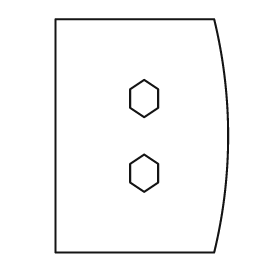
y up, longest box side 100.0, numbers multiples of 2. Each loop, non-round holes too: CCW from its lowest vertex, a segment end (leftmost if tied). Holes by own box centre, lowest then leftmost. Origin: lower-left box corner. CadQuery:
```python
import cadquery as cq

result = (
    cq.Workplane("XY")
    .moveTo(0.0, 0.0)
    .lineTo(68.0, 0.0)
    .threePointArc((74.0, 50.0), (68.0, 100.0))
    .lineTo(0.0, 100.0)
    .close()
    .moveTo(38.0, 26.0)
    .lineTo(44.0, 30.0)
    .lineTo(44.0, 38.0)
    .lineTo(38.0, 42.0)
    .lineTo(32.0, 38.0)
    .lineTo(32.0, 30.0)
    .close()
    .moveTo(38.0, 58.0)
    .lineTo(44.0, 62.0)
    .lineTo(44.0, 70.0)
    .lineTo(38.0, 74.0)
    .lineTo(32.0, 70.0)
    .lineTo(32.0, 62.0)
    .close()
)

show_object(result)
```